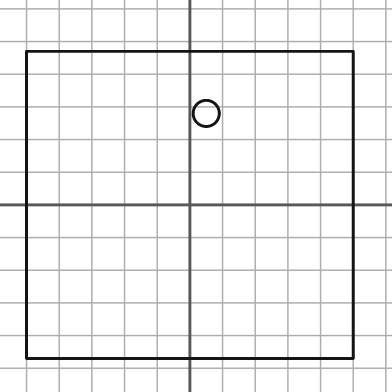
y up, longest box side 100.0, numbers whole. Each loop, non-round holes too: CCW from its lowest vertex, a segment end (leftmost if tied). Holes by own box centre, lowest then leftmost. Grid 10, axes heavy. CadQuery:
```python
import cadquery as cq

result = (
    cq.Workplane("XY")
    .moveTo(-50.0, -47.0)
    .lineTo(50.0, -47.0)
    .lineTo(50.0, 47.0)
    .lineTo(-50.0, 47.0)
    .close()
    .moveTo(5.0, 28.0)
    .circle(4.0)
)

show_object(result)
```